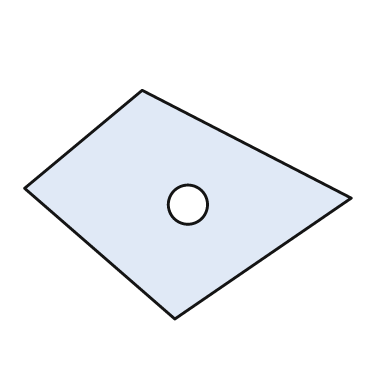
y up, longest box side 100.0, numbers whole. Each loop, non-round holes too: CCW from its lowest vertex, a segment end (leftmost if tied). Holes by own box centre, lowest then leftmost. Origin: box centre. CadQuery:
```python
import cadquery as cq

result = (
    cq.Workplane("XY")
    .moveTo(-4.0, -35.0)
    .lineTo(50.0, 2.0)
    .lineTo(-14.0, 35.0)
    .lineTo(-50.0, 5.0)
    .close()
    .moveTo(0.0, 0.0)
    .circle(6.0)
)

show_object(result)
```